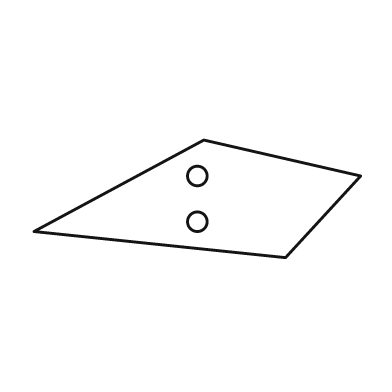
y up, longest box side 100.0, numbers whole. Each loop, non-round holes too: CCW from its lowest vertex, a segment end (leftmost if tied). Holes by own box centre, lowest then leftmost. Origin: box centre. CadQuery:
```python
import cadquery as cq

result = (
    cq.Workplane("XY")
    .moveTo(27.0, -18.0)
    .lineTo(50.0, 7.0)
    .lineTo(2.0, 18.0)
    .lineTo(-50.0, -10.0)
    .close()
    .moveTo(0.0, -7.0)
    .circle(3.0)
    .moveTo(0.0, 7.0)
    .circle(3.0)
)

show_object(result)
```